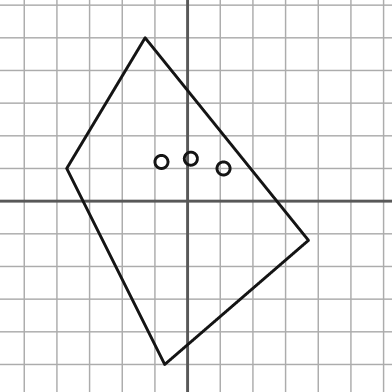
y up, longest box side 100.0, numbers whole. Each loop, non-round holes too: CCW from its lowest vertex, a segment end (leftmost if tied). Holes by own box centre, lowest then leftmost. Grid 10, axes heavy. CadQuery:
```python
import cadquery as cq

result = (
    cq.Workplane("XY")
    .moveTo(-7.0, -50.0)
    .lineTo(37.0, -12.0)
    .lineTo(-13.0, 50.0)
    .lineTo(-37.0, 10.0)
    .close()
    .moveTo(11.0, 10.0)
    .circle(2.0)
    .moveTo(-8.0, 12.0)
    .circle(2.0)
    .moveTo(1.0, 13.0)
    .circle(2.0)
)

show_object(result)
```